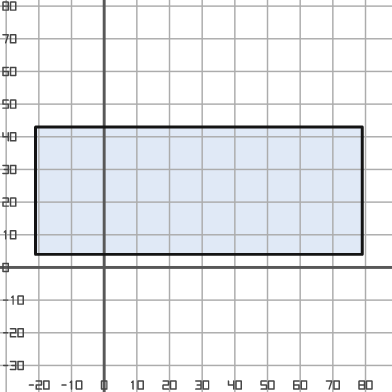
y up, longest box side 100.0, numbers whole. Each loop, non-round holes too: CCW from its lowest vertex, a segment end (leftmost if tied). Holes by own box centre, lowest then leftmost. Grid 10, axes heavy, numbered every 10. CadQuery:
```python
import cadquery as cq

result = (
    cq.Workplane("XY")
    .moveTo(-21.0, 4.0)
    .lineTo(79.0, 4.0)
    .lineTo(79.0, 43.0)
    .lineTo(-21.0, 43.0)
    .close()
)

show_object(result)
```